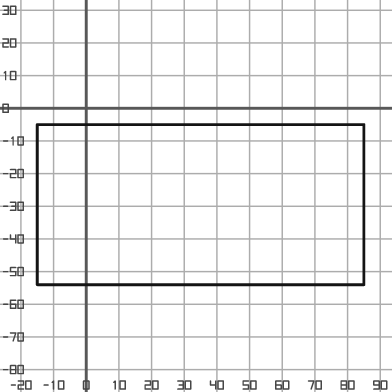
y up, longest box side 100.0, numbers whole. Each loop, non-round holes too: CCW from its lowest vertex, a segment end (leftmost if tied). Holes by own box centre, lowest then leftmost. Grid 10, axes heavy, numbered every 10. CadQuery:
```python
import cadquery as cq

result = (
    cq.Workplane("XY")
    .moveTo(-15.0, -54.0)
    .lineTo(85.0, -54.0)
    .lineTo(85.0, -5.0)
    .lineTo(-15.0, -5.0)
    .close()
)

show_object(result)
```